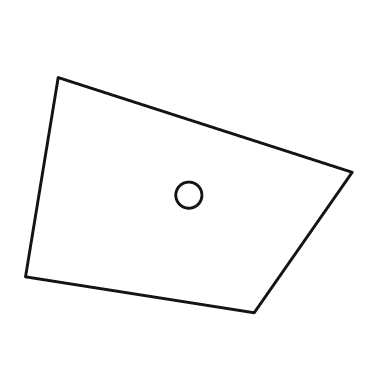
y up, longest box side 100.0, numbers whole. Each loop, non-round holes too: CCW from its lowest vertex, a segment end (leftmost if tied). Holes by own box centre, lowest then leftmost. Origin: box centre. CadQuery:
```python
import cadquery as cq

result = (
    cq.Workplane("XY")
    .moveTo(20.0, -36.0)
    .lineTo(50.0, 7.0)
    .lineTo(-40.0, 36.0)
    .lineTo(-50.0, -25.0)
    .close()
    .moveTo(0.0, 0.0)
    .circle(4.0)
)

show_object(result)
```